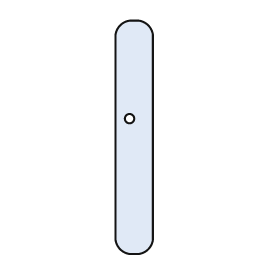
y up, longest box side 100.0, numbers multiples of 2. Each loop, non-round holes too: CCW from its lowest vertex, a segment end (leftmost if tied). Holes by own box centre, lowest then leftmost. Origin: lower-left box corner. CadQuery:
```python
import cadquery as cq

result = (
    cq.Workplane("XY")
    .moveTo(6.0, 0.0)
    .lineTo(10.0, 0.0)
    .threePointArc((14.0, 2.0), (16.0, 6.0))
    .lineTo(16.0, 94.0)
    .threePointArc((14.0, 98.0), (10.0, 100.0))
    .lineTo(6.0, 100.0)
    .threePointArc((2.0, 98.0), (0.0, 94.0))
    .lineTo(0.0, 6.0)
    .threePointArc((2.0, 2.0), (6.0, 0.0))
    .close()
    .moveTo(6.0, 58.0)
    .circle(2.0)
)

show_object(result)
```